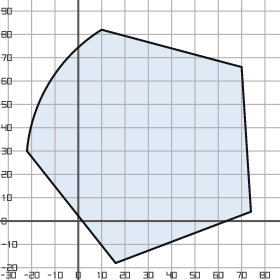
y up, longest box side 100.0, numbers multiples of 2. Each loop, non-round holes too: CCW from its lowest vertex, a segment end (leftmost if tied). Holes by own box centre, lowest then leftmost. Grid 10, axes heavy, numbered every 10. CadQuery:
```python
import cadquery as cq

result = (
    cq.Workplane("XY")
    .moveTo(16.0, -18.0)
    .lineTo(74.0, 4.0)
    .lineTo(70.0, 66.0)
    .lineTo(10.0, 82.0)
    .threePointArc((-12.0, 60.0), (-22.0, 30.0))
    .close()
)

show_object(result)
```